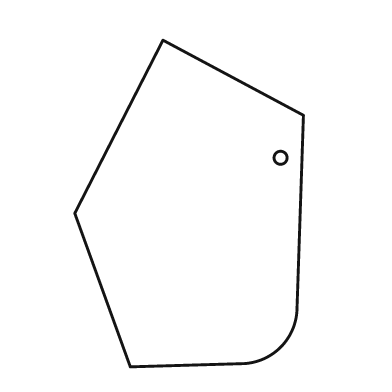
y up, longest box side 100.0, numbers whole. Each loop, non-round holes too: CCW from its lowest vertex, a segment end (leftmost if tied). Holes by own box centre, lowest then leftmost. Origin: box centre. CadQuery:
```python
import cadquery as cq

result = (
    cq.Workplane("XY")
    .moveTo(-18.0, -50.0)
    .lineTo(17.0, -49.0)
    .threePointArc((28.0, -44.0), (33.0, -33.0))
    .lineTo(35.0, 27.0)
    .lineTo(-8.0, 50.0)
    .lineTo(-35.0, -3.0)
    .close()
    .moveTo(28.0, 14.0)
    .circle(2.0)
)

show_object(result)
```